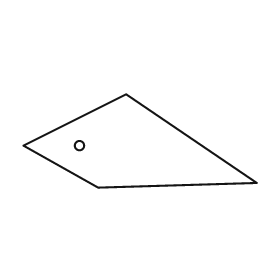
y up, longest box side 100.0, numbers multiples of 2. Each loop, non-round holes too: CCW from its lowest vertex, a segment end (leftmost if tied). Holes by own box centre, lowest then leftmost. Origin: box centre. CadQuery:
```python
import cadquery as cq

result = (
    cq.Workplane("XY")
    .moveTo(-18.0, -20.0)
    .lineTo(50.0, -18.0)
    .lineTo(-6.0, 20.0)
    .lineTo(-50.0, -2.0)
    .close()
    .moveTo(-26.0, -2.0)
    .circle(2.0)
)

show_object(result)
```